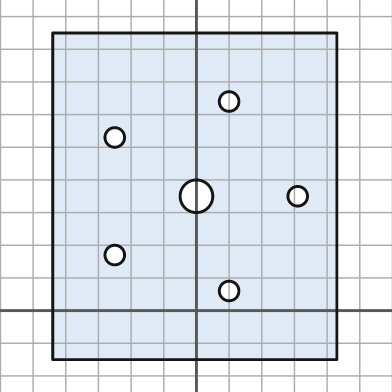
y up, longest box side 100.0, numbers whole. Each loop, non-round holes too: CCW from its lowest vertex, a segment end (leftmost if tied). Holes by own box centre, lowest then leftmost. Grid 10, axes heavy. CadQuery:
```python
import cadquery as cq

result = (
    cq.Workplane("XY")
    .moveTo(-44.0, -15.0)
    .lineTo(43.0, -15.0)
    .lineTo(43.0, 85.0)
    .lineTo(-44.0, 85.0)
    .close()
    .moveTo(10.0, 6.0)
    .circle(3.0)
    .moveTo(-25.0, 17.0)
    .circle(3.0)
    .moveTo(0.0, 35.0)
    .circle(5.0)
    .moveTo(31.0, 35.0)
    .circle(3.0)
    .moveTo(-25.0, 53.0)
    .circle(3.0)
    .moveTo(10.0, 64.0)
    .circle(3.0)
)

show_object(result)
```